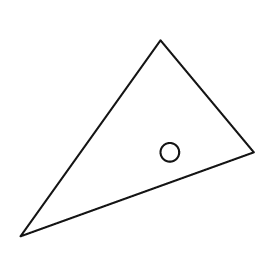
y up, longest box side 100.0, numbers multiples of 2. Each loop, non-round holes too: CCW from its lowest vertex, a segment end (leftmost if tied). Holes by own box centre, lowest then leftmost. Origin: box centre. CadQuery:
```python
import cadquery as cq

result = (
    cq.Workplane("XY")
    .moveTo(-50.0, -42.0)
    .lineTo(50.0, -6.0)
    .lineTo(10.0, 42.0)
    .close()
    .moveTo(14.0, -6.0)
    .circle(4.0)
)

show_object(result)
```